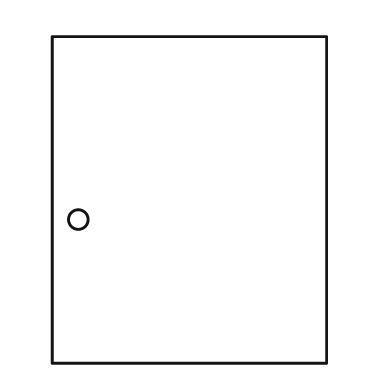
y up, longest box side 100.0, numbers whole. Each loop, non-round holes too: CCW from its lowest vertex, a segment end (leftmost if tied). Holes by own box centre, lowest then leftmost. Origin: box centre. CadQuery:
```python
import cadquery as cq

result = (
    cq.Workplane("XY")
    .moveTo(-42.0, -50.0)
    .lineTo(42.0, -50.0)
    .lineTo(42.0, 50.0)
    .lineTo(-42.0, 50.0)
    .close()
    .moveTo(-34.0, -6.0)
    .circle(3.0)
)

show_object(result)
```